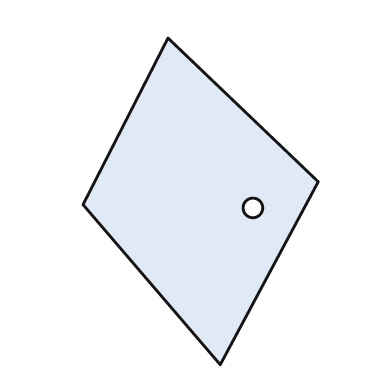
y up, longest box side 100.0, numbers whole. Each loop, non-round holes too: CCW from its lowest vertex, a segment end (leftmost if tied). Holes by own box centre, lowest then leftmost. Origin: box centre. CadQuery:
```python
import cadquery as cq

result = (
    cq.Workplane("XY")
    .moveTo(6.0, -50.0)
    .lineTo(36.0, 6.0)
    .lineTo(-10.0, 50.0)
    .lineTo(-36.0, -1.0)
    .close()
    .moveTo(16.0, -2.0)
    .circle(3.0)
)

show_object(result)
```